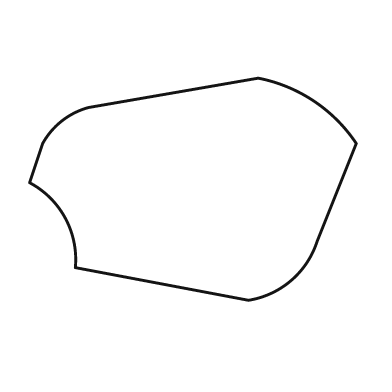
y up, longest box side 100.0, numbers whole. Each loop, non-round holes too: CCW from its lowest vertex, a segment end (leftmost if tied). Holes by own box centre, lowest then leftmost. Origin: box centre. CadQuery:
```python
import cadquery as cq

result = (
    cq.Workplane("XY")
    .moveTo(17.0, -34.0)
    .threePointArc((30.0, -28.0), (38.0, -16.0))
    .lineTo(50.0, 14.0)
    .threePointArc((37.0, 27.0), (20.0, 34.0))
    .lineTo(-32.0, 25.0)
    .threePointArc((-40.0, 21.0), (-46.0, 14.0))
    .lineTo(-50.0, 2.0)
    .threePointArc((-39.0, -9.0), (-36.0, -24.0))
    .close()
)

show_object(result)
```